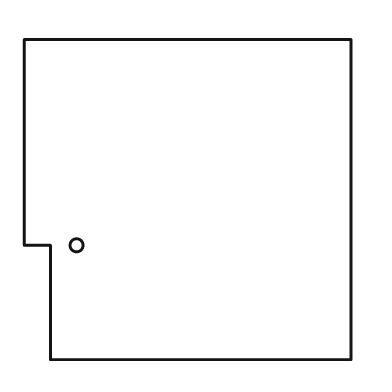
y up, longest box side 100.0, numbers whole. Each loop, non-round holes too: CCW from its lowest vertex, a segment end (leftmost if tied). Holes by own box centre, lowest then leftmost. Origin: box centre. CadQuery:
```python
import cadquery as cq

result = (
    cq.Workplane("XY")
    .moveTo(-42.0, -49.0)
    .lineTo(50.0, -49.0)
    .lineTo(50.0, 49.0)
    .lineTo(-50.0, 49.0)
    .lineTo(-50.0, -14.0)
    .lineTo(-42.0, -14.0)
    .close()
    .moveTo(-34.0, -14.0)
    .circle(2.0)
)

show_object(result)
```